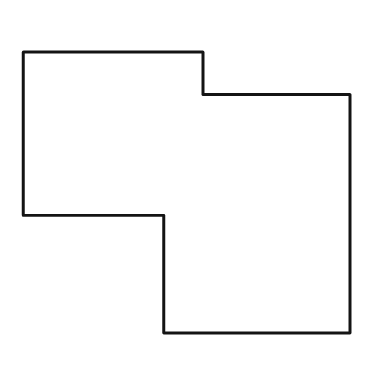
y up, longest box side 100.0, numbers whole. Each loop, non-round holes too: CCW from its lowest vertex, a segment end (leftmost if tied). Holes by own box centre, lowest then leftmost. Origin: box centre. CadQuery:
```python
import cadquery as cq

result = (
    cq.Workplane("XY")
    .moveTo(-7.0, -43.0)
    .lineTo(50.0, -43.0)
    .lineTo(50.0, 30.0)
    .lineTo(5.0, 30.0)
    .lineTo(5.0, 43.0)
    .lineTo(-50.0, 43.0)
    .lineTo(-50.0, -7.0)
    .lineTo(-7.0, -7.0)
    .close()
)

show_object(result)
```